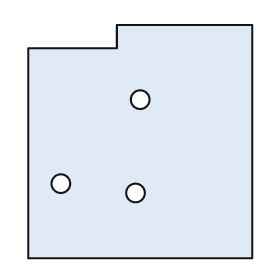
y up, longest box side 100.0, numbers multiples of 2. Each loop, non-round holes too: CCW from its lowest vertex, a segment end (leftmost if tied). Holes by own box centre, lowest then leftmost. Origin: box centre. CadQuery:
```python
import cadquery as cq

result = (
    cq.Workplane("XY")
    .moveTo(-48.0, -50.0)
    .lineTo(48.0, -50.0)
    .lineTo(48.0, 50.0)
    .lineTo(-10.0, 50.0)
    .lineTo(-10.0, 40.0)
    .lineTo(-48.0, 40.0)
    .close()
    .moveTo(-2.0, -22.0)
    .circle(4.0)
    .moveTo(-34.0, -18.0)
    .circle(4.0)
    .moveTo(0.0, 18.0)
    .circle(4.0)
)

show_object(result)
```